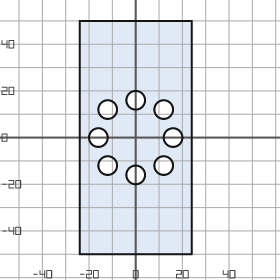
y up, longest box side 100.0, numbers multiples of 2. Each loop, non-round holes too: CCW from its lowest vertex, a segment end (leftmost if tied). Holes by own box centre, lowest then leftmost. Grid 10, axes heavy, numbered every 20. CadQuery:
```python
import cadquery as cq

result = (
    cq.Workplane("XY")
    .moveTo(-24.0, -50.0)
    .lineTo(24.0, -50.0)
    .lineTo(24.0, 50.0)
    .lineTo(-24.0, 50.0)
    .close()
    .moveTo(0.0, -16.0)
    .circle(4.0)
    .moveTo(-12.0, -12.0)
    .circle(4.0)
    .moveTo(12.0, -12.0)
    .circle(4.0)
    .moveTo(-16.0, 0.0)
    .circle(4.0)
    .moveTo(16.0, 0.0)
    .circle(4.0)
    .moveTo(-12.0, 12.0)
    .circle(4.0)
    .moveTo(12.0, 12.0)
    .circle(4.0)
    .moveTo(0.0, 16.0)
    .circle(4.0)
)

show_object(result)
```